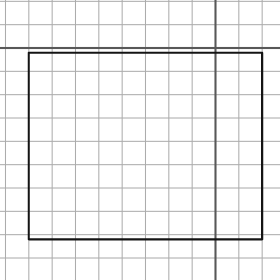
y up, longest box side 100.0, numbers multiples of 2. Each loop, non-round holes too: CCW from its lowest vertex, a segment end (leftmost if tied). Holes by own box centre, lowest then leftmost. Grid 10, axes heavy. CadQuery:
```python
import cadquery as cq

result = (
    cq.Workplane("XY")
    .moveTo(-80.0, -82.0)
    .lineTo(20.0, -82.0)
    .lineTo(20.0, -2.0)
    .lineTo(-80.0, -2.0)
    .close()
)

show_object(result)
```